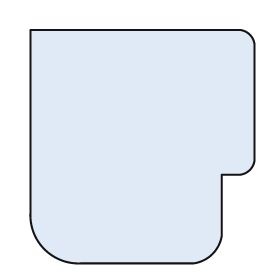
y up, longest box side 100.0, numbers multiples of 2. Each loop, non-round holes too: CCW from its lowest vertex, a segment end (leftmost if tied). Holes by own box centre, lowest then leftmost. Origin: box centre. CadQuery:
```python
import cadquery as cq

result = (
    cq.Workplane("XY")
    .moveTo(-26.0, -50.0)
    .lineTo(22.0, -50.0)
    .threePointArc((30.0, -46.0), (34.0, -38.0))
    .lineTo(34.0, -12.0)
    .lineTo(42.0, -12.0)
    .threePointArc((46.0, -10.0), (48.0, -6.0))
    .lineTo(48.0, 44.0)
    .threePointArc((46.0, 48.0), (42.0, 50.0))
    .lineTo(-48.0, 50.0)
    .lineTo(-48.0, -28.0)
    .threePointArc((-42.0, -44.0), (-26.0, -50.0))
    .close()
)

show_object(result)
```